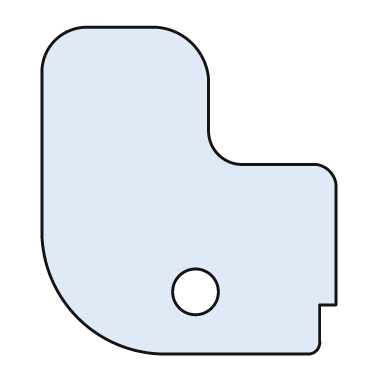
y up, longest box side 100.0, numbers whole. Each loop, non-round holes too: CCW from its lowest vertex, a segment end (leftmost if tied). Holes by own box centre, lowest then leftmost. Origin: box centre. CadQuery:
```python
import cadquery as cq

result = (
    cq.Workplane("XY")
    .moveTo(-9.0, -50.0)
    .lineTo(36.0, -50.0)
    .threePointArc((39.0, -49.0), (40.0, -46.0))
    .lineTo(40.0, -35.0)
    .lineTo(45.0, -35.0)
    .lineTo(45.0, 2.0)
    .threePointArc((43.0, 6.0), (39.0, 8.0))
    .lineTo(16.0, 8.0)
    .threePointArc((9.0, 11.0), (6.0, 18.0))
    .lineTo(6.0, 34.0)
    .threePointArc((1.0, 45.0), (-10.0, 50.0))
    .lineTo(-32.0, 50.0)
    .threePointArc((-41.0, 46.0), (-45.0, 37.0))
    .lineTo(-45.0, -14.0)
    .threePointArc((-34.0, -39.0), (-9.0, -50.0))
    .close()
    .moveTo(2.0, -31.0)
    .circle(7.0)
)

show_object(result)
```